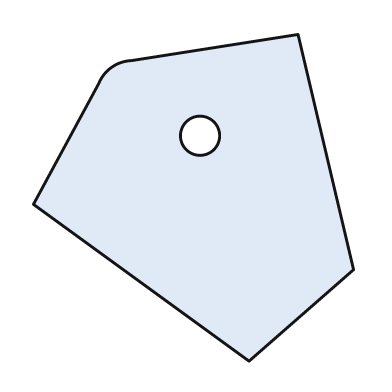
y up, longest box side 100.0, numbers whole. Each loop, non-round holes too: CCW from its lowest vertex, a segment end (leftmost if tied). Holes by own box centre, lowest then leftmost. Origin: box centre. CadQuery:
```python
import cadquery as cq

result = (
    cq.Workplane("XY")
    .moveTo(17.0, -50.0)
    .lineTo(49.0, -22.0)
    .lineTo(32.0, 50.0)
    .lineTo(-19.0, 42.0)
    .threePointArc((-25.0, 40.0), (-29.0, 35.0))
    .lineTo(-49.0, -2.0)
    .close()
    .moveTo(2.0, 19.0)
    .circle(6.0)
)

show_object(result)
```